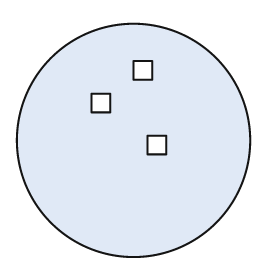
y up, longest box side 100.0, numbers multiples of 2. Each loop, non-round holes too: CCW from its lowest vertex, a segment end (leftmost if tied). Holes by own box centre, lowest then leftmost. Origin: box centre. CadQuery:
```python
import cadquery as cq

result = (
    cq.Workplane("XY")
    .moveTo(0.0, 0.0)
    .circle(50.0)
    .moveTo(6.0, -6.0)
    .lineTo(14.0, -6.0)
    .lineTo(14.0, 2.0)
    .lineTo(6.0, 2.0)
    .close()
    .moveTo(-18.0, 12.0)
    .lineTo(-10.0, 12.0)
    .lineTo(-10.0, 20.0)
    .lineTo(-18.0, 20.0)
    .close()
    .moveTo(0.0, 26.0)
    .lineTo(8.0, 26.0)
    .lineTo(8.0, 34.0)
    .lineTo(0.0, 34.0)
    .close()
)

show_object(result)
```